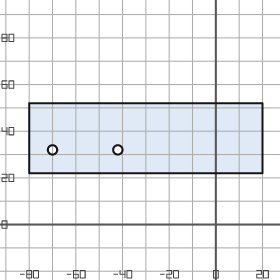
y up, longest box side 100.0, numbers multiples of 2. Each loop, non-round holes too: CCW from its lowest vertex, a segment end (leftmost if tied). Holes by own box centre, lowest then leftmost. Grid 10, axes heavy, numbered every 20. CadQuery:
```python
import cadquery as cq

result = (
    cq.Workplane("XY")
    .moveTo(-80.0, 22.0)
    .lineTo(20.0, 22.0)
    .lineTo(20.0, 52.0)
    .lineTo(-80.0, 52.0)
    .close()
    .moveTo(-70.0, 32.0)
    .circle(2.0)
    .moveTo(-42.0, 32.0)
    .circle(2.0)
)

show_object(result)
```